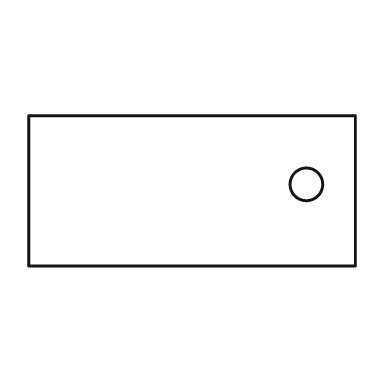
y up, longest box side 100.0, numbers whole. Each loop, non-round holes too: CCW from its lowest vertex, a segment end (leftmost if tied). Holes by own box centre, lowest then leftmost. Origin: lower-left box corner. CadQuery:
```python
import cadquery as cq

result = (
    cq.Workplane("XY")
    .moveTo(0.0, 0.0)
    .lineTo(100.0, 0.0)
    .lineTo(100.0, 46.0)
    .lineTo(0.0, 46.0)
    .close()
    .moveTo(85.0, 25.0)
    .circle(5.0)
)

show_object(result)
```